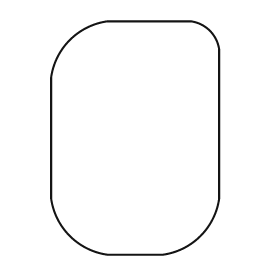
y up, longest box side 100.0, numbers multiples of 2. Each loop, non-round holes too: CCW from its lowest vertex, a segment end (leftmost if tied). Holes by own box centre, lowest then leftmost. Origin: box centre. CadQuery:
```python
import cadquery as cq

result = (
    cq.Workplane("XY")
    .moveTo(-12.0, -50.0)
    .lineTo(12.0, -50.0)
    .threePointArc((28.0, -42.0), (36.0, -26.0))
    .lineTo(36.0, 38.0)
    .threePointArc((32.0, 46.0), (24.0, 50.0))
    .lineTo(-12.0, 50.0)
    .threePointArc((-28.0, 42.0), (-36.0, 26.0))
    .lineTo(-36.0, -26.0)
    .threePointArc((-28.0, -42.0), (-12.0, -50.0))
    .close()
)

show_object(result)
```